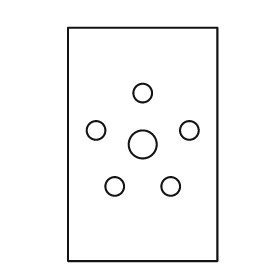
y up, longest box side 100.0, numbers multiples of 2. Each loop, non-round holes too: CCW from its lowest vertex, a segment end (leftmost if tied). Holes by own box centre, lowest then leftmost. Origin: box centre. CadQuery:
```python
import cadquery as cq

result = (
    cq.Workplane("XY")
    .moveTo(-32.0, -50.0)
    .lineTo(32.0, -50.0)
    .lineTo(32.0, 50.0)
    .lineTo(-32.0, 50.0)
    .close()
    .moveTo(-12.0, -18.0)
    .circle(4.0)
    .moveTo(12.0, -18.0)
    .circle(4.0)
    .moveTo(0.0, 0.0)
    .circle(6.0)
    .moveTo(-20.0, 6.0)
    .circle(4.0)
    .moveTo(20.0, 6.0)
    .circle(4.0)
    .moveTo(0.0, 22.0)
    .circle(4.0)
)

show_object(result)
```